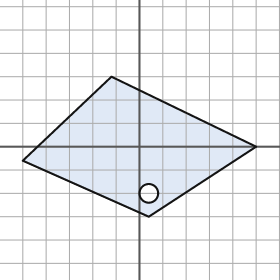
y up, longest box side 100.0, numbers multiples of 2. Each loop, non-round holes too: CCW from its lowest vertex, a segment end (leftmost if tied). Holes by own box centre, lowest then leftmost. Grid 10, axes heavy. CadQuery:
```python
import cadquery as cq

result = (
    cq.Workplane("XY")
    .moveTo(4.0, -30.0)
    .lineTo(50.0, 0.0)
    .lineTo(-12.0, 30.0)
    .lineTo(-50.0, -6.0)
    .close()
    .moveTo(4.0, -20.0)
    .circle(4.0)
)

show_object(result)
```